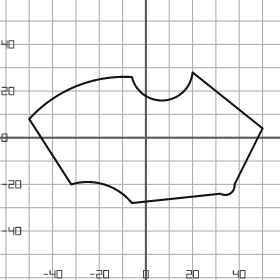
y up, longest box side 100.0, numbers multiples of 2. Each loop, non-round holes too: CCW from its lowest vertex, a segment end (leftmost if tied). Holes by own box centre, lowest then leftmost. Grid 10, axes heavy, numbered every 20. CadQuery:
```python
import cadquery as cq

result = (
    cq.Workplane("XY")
    .moveTo(-6.0, -28.0)
    .lineTo(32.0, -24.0)
    .threePointArc((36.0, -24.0), (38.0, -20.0))
    .lineTo(50.0, 4.0)
    .lineTo(20.0, 28.0)
    .threePointArc((8.0, 16.0), (-6.0, 26.0))
    .threePointArc((-30.0, 22.0), (-50.0, 8.0))
    .lineTo(-32.0, -20.0)
    .threePointArc((-18.0, -20.0), (-6.0, -28.0))
    .close()
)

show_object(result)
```